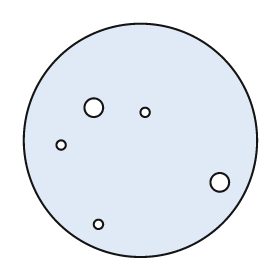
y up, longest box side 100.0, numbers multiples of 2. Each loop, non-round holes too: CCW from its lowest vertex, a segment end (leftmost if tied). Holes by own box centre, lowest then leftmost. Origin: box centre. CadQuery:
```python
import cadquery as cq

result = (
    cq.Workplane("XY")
    .moveTo(0.0, 0.0)
    .circle(50.0)
    .moveTo(-18.0, -36.0)
    .circle(2.0)
    .moveTo(34.0, -18.0)
    .circle(4.0)
    .moveTo(-34.0, -2.0)
    .circle(2.0)
    .moveTo(2.0, 12.0)
    .circle(2.0)
    .moveTo(-20.0, 14.0)
    .circle(4.0)
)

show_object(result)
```